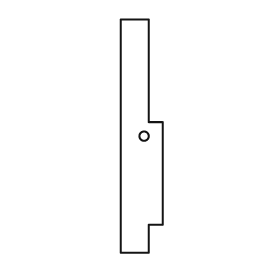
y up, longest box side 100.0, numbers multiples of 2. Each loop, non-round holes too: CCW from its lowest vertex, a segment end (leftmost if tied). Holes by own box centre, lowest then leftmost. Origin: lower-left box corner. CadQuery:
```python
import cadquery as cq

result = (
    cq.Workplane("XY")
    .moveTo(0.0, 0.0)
    .lineTo(12.0, 0.0)
    .lineTo(12.0, 12.0)
    .lineTo(18.0, 12.0)
    .lineTo(18.0, 56.0)
    .lineTo(12.0, 56.0)
    .lineTo(12.0, 100.0)
    .lineTo(0.0, 100.0)
    .close()
    .moveTo(10.0, 50.0)
    .circle(2.0)
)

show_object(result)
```